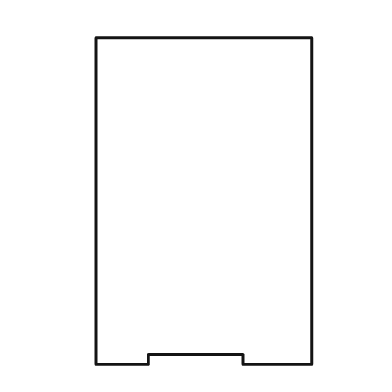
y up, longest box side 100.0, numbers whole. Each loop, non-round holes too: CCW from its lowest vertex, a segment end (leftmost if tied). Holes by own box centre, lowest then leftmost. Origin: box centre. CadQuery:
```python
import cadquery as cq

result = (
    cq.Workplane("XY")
    .moveTo(-33.0, -50.0)
    .lineTo(-17.0, -50.0)
    .lineTo(-17.0, -47.0)
    .lineTo(12.0, -47.0)
    .lineTo(12.0, -50.0)
    .lineTo(33.0, -50.0)
    .lineTo(33.0, 50.0)
    .lineTo(-33.0, 50.0)
    .close()
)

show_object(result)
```